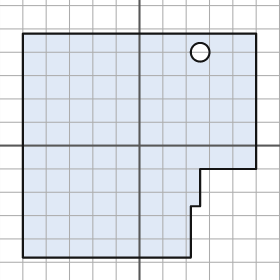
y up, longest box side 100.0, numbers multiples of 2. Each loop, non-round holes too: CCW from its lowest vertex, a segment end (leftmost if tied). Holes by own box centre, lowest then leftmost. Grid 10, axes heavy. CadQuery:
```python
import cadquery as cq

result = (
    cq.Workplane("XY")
    .moveTo(-50.0, -48.0)
    .lineTo(22.0, -48.0)
    .lineTo(22.0, -26.0)
    .lineTo(26.0, -26.0)
    .lineTo(26.0, -10.0)
    .lineTo(50.0, -10.0)
    .lineTo(50.0, 48.0)
    .lineTo(-50.0, 48.0)
    .close()
    .moveTo(26.0, 40.0)
    .circle(4.0)
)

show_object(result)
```